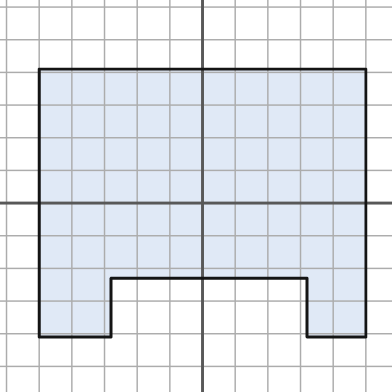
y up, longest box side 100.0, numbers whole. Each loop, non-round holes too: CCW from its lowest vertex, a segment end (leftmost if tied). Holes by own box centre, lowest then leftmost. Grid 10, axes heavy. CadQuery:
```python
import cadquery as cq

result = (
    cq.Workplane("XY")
    .moveTo(-50.0, -41.0)
    .lineTo(-28.0, -41.0)
    .lineTo(-28.0, -23.0)
    .lineTo(32.0, -23.0)
    .lineTo(32.0, -41.0)
    .lineTo(50.0, -41.0)
    .lineTo(50.0, 41.0)
    .lineTo(-50.0, 41.0)
    .close()
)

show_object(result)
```